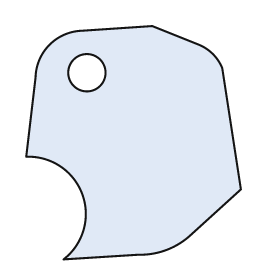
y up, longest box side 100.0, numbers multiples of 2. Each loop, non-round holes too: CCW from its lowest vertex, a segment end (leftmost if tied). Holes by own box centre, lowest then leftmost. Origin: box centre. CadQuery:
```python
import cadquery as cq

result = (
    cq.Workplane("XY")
    .moveTo(-30.0, -50.0)
    .lineTo(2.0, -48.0)
    .threePointArc((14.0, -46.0), (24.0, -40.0))
    .lineTo(46.0, -20.0)
    .lineTo(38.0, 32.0)
    .threePointArc((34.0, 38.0), (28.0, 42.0))
    .lineTo(8.0, 50.0)
    .lineTo(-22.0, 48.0)
    .threePointArc((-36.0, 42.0), (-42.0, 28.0))
    .lineTo(-46.0, -6.0)
    .threePointArc((-22.0, -22.0), (-30.0, -50.0))
    .close()
    .moveTo(-20.0, 30.0)
    .circle(8.0)
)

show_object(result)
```